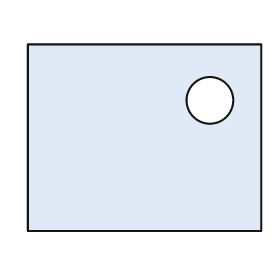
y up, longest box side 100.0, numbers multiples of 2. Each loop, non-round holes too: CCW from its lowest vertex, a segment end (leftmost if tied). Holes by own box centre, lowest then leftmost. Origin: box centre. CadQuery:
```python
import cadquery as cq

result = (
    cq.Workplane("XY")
    .moveTo(-50.0, -40.0)
    .lineTo(50.0, -40.0)
    .lineTo(50.0, 40.0)
    .lineTo(-50.0, 40.0)
    .close()
    .moveTo(28.0, 16.0)
    .circle(10.0)
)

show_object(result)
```